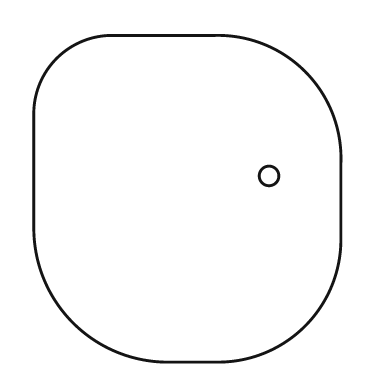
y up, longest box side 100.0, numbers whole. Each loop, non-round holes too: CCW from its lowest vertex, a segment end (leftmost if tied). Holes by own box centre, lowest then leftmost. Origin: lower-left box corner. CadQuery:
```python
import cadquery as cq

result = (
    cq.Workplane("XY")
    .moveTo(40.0, 0.0)
    .lineTo(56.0, 0.0)
    .threePointArc((83.0, 11.0), (94.0, 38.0))
    .lineTo(94.0, 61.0)
    .threePointArc((83.0, 89.0), (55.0, 100.0))
    .lineTo(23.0, 100.0)
    .threePointArc((7.0, 93.0), (0.0, 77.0))
    .lineTo(0.0, 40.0)
    .threePointArc((12.0, 12.0), (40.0, 0.0))
    .close()
    .moveTo(72.0, 57.0)
    .circle(3.0)
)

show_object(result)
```